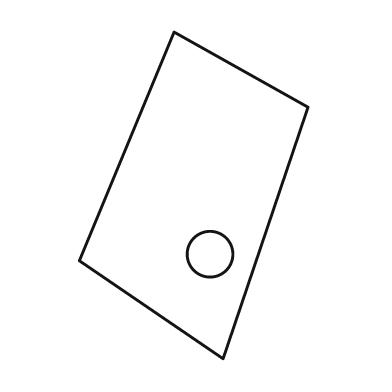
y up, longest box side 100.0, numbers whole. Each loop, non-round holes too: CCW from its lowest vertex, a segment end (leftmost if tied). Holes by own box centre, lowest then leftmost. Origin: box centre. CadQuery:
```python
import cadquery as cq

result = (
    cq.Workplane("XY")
    .moveTo(9.0, -50.0)
    .lineTo(35.0, 27.0)
    .lineTo(-6.0, 50.0)
    .lineTo(-35.0, -20.0)
    .close()
    .moveTo(5.0, -18.0)
    .circle(7.0)
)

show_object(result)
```